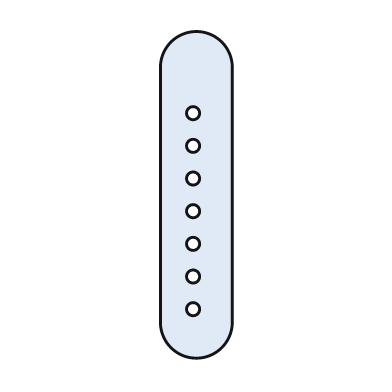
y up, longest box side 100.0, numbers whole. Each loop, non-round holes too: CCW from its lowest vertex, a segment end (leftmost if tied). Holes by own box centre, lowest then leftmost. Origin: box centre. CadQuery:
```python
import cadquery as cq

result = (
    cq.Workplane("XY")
    .moveTo(-11.0, -39.0)
    .threePointArc((0.0, -50.0), (11.0, -39.0))
    .lineTo(11.0, 39.0)
    .threePointArc((0.0, 50.0), (-11.0, 39.0))
    .close()
    .moveTo(-1.0, -35.0)
    .circle(2.0)
    .moveTo(-1.0, -25.0)
    .circle(2.0)
    .moveTo(-1.0, -15.0)
    .circle(2.0)
    .moveTo(-1.0, -5.0)
    .circle(2.0)
    .moveTo(-1.0, 5.0)
    .circle(2.0)
    .moveTo(-1.0, 15.0)
    .circle(2.0)
    .moveTo(-1.0, 25.0)
    .circle(2.0)
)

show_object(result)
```